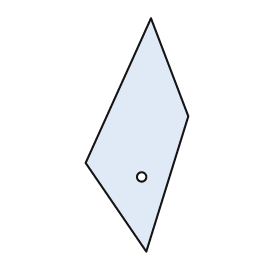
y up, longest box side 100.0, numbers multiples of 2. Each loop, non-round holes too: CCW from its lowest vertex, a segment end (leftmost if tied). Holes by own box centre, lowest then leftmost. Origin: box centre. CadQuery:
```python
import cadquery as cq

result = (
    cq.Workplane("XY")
    .moveTo(4.0, -50.0)
    .lineTo(22.0, 8.0)
    .lineTo(6.0, 50.0)
    .lineTo(-22.0, -12.0)
    .close()
    .moveTo(2.0, -18.0)
    .circle(2.0)
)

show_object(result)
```